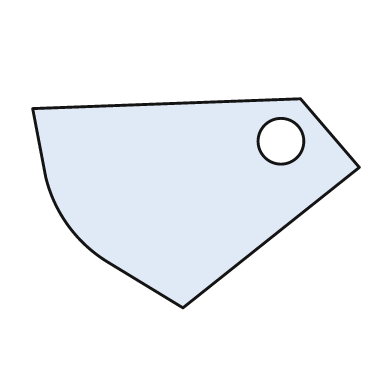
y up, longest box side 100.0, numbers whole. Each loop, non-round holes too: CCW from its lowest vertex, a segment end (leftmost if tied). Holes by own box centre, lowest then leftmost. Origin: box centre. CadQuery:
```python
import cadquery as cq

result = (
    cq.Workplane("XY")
    .moveTo(-4.0, -32.0)
    .lineTo(50.0, 11.0)
    .lineTo(32.0, 32.0)
    .lineTo(-50.0, 29.0)
    .lineTo(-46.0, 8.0)
    .threePointArc((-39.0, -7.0), (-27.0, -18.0))
    .close()
    .moveTo(26.0, 19.0)
    .circle(7.0)
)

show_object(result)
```